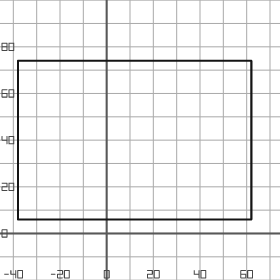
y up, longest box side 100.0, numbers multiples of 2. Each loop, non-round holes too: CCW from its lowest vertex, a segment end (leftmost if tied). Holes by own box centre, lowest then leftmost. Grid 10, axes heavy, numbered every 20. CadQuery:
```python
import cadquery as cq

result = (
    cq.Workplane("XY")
    .moveTo(-38.0, 6.0)
    .lineTo(62.0, 6.0)
    .lineTo(62.0, 74.0)
    .lineTo(-38.0, 74.0)
    .close()
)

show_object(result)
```